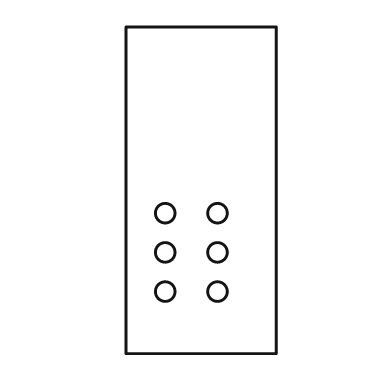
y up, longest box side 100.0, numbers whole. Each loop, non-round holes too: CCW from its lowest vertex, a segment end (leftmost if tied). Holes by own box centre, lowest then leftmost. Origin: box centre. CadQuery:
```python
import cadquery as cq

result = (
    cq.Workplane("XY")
    .moveTo(-23.0, -50.0)
    .lineTo(23.0, -50.0)
    .lineTo(23.0, 50.0)
    .lineTo(-23.0, 50.0)
    .close()
    .moveTo(-11.0, -31.0)
    .circle(3.0)
    .moveTo(5.0, -31.0)
    .circle(3.0)
    .moveTo(-11.0, -19.0)
    .circle(3.0)
    .moveTo(5.0, -19.0)
    .circle(3.0)
    .moveTo(-11.0, -7.0)
    .circle(3.0)
    .moveTo(5.0, -7.0)
    .circle(3.0)
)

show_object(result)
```